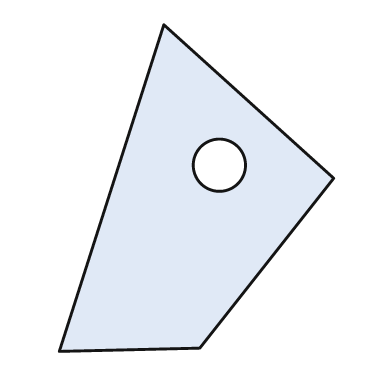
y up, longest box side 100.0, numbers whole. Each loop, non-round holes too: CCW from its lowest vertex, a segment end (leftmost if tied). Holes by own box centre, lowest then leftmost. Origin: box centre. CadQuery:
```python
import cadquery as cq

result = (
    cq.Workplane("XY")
    .moveTo(-42.0, -50.0)
    .lineTo(1.0, -49.0)
    .lineTo(42.0, 3.0)
    .lineTo(-10.0, 50.0)
    .close()
    .moveTo(7.0, 7.0)
    .circle(8.0)
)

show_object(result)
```